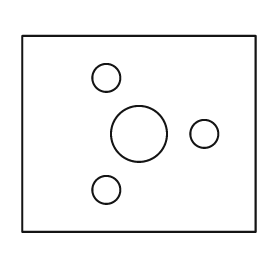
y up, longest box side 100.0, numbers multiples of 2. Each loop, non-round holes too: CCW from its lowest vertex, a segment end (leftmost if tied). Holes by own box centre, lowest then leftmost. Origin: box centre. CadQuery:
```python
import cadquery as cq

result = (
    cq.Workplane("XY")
    .moveTo(-50.0, -42.0)
    .lineTo(50.0, -42.0)
    .lineTo(50.0, 42.0)
    .lineTo(-50.0, 42.0)
    .close()
    .moveTo(-14.0, -24.0)
    .circle(6.0)
    .moveTo(0.0, 0.0)
    .circle(12.0)
    .moveTo(28.0, 0.0)
    .circle(6.0)
    .moveTo(-14.0, 24.0)
    .circle(6.0)
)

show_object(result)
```